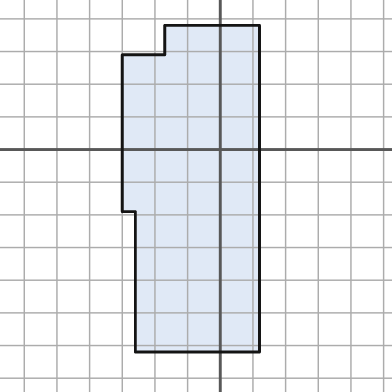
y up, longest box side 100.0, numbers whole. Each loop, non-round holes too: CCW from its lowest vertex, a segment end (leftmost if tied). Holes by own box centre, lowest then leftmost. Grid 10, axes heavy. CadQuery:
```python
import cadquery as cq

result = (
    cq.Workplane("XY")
    .moveTo(-26.0, -62.0)
    .lineTo(12.0, -62.0)
    .lineTo(12.0, 38.0)
    .lineTo(-17.0, 38.0)
    .lineTo(-17.0, 29.0)
    .lineTo(-30.0, 29.0)
    .lineTo(-30.0, -19.0)
    .lineTo(-26.0, -19.0)
    .close()
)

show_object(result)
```